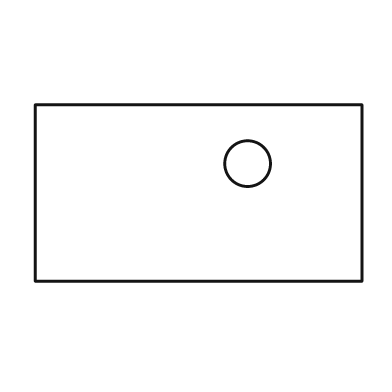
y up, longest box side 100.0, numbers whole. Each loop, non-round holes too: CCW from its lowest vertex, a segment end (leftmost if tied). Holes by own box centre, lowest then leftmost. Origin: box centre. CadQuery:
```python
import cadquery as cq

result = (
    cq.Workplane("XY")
    .moveTo(-50.0, -27.0)
    .lineTo(50.0, -27.0)
    .lineTo(50.0, 27.0)
    .lineTo(-50.0, 27.0)
    .close()
    .moveTo(15.0, 9.0)
    .circle(7.0)
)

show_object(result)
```